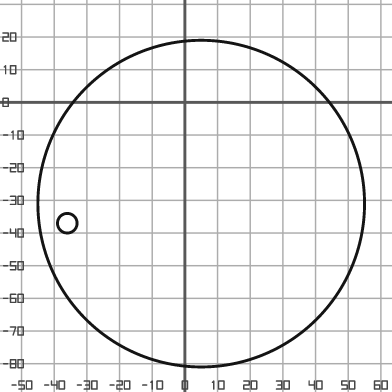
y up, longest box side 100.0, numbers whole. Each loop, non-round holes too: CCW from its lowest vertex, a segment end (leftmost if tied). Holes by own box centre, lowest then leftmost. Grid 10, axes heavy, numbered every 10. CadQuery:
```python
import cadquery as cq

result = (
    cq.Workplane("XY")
    .moveTo(5.0, -31.0)
    .circle(50.0)
    .moveTo(-36.0, -37.0)
    .circle(3.0)
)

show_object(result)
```